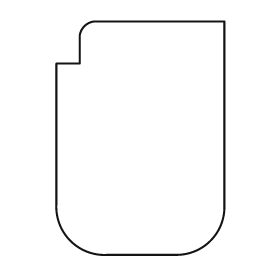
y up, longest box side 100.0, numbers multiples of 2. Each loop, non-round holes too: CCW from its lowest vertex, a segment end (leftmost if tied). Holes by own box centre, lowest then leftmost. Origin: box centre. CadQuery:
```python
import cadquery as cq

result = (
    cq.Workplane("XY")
    .moveTo(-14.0, -50.0)
    .lineTo(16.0, -50.0)
    .threePointArc((30.0, -44.0), (36.0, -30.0))
    .lineTo(36.0, 50.0)
    .lineTo(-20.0, 50.0)
    .threePointArc((-24.0, 48.0), (-26.0, 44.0))
    .lineTo(-26.0, 32.0)
    .lineTo(-36.0, 32.0)
    .lineTo(-36.0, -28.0)
    .threePointArc((-30.0, -44.0), (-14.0, -50.0))
    .close()
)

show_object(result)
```